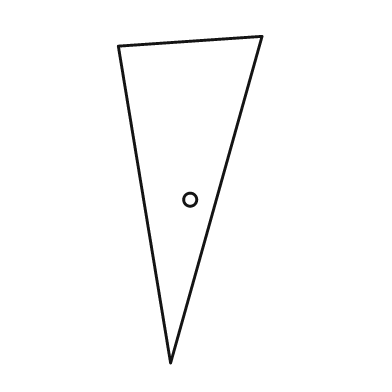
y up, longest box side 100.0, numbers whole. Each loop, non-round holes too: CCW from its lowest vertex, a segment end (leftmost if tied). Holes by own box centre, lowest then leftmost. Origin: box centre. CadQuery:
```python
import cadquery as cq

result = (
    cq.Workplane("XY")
    .moveTo(-6.0, -50.0)
    .lineTo(22.0, 50.0)
    .lineTo(-22.0, 47.0)
    .close()
    .moveTo(0.0, 0.0)
    .circle(2.0)
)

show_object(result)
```